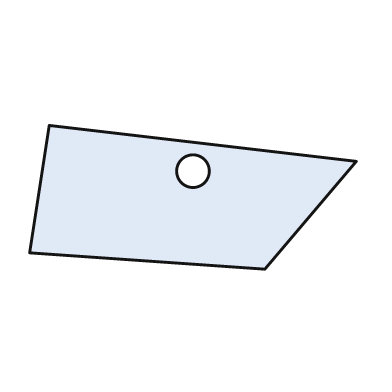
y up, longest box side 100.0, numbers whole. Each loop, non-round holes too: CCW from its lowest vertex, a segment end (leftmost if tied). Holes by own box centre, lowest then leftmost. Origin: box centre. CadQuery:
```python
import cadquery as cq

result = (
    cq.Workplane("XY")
    .moveTo(22.0, -22.0)
    .lineTo(50.0, 11.0)
    .lineTo(-44.0, 22.0)
    .lineTo(-50.0, -17.0)
    .close()
    .moveTo(0.0, 8.0)
    .circle(5.0)
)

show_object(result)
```